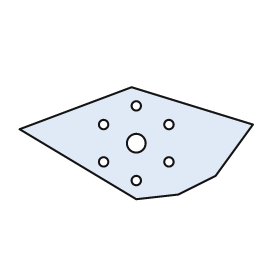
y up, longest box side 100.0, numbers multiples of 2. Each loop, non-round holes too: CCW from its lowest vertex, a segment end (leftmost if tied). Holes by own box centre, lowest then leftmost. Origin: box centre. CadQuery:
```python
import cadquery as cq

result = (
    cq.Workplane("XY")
    .moveTo(0.0, -24.0)
    .lineTo(18.0, -22.0)
    .lineTo(34.0, -14.0)
    .lineTo(50.0, 8.0)
    .lineTo(-2.0, 24.0)
    .lineTo(-50.0, 6.0)
    .close()
    .moveTo(0.0, -16.0)
    .circle(2.0)
    .moveTo(-14.0, -8.0)
    .circle(2.0)
    .moveTo(14.0, -8.0)
    .circle(2.0)
    .moveTo(0.0, 0.0)
    .circle(4.0)
    .moveTo(-14.0, 8.0)
    .circle(2.0)
    .moveTo(14.0, 8.0)
    .circle(2.0)
    .moveTo(0.0, 16.0)
    .circle(2.0)
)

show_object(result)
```